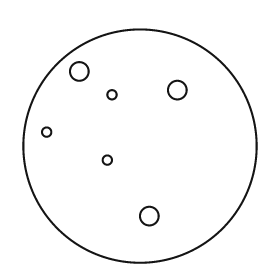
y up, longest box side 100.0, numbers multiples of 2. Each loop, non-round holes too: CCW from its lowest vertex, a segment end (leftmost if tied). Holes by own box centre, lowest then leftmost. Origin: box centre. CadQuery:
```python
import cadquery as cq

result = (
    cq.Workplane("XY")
    .moveTo(0.0, 0.0)
    .circle(50.0)
    .moveTo(4.0, -30.0)
    .circle(4.0)
    .moveTo(-14.0, -6.0)
    .circle(2.0)
    .moveTo(-40.0, 6.0)
    .circle(2.0)
    .moveTo(-12.0, 22.0)
    .circle(2.0)
    .moveTo(16.0, 24.0)
    .circle(4.0)
    .moveTo(-26.0, 32.0)
    .circle(4.0)
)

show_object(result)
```